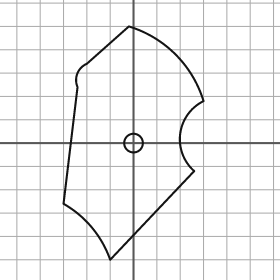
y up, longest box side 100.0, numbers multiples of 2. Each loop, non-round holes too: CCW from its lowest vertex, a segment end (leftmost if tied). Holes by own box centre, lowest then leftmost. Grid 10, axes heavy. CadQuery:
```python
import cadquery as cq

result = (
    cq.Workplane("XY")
    .moveTo(-10.0, -50.0)
    .lineTo(26.0, -12.0)
    .threePointArc((20.0, 4.0), (30.0, 18.0))
    .threePointArc((18.0, 38.0), (-2.0, 50.0))
    .lineTo(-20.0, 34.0)
    .threePointArc((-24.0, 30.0), (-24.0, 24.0))
    .lineTo(-30.0, -26.0)
    .threePointArc((-18.0, -36.0), (-10.0, -50.0))
    .close()
    .moveTo(0.0, 0.0)
    .circle(4.0)
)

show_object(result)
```